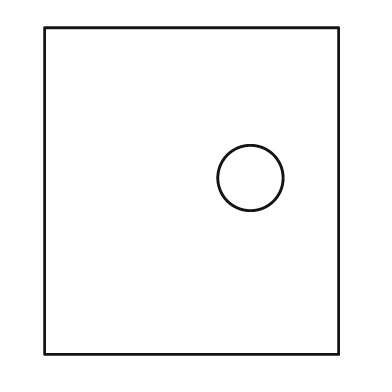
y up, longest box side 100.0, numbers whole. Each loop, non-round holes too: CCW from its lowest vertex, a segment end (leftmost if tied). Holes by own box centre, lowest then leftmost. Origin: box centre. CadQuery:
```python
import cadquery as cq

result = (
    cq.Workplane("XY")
    .moveTo(-45.0, -50.0)
    .lineTo(45.0, -50.0)
    .lineTo(45.0, 50.0)
    .lineTo(-45.0, 50.0)
    .close()
    .moveTo(18.0, 4.0)
    .circle(10.0)
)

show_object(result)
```